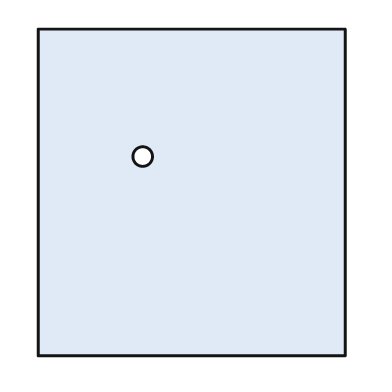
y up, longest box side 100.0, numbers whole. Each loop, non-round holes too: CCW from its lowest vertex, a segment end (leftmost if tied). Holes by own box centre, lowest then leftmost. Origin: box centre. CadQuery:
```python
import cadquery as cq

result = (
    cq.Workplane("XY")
    .moveTo(-47.0, -50.0)
    .lineTo(47.0, -50.0)
    .lineTo(47.0, 50.0)
    .lineTo(-47.0, 50.0)
    .close()
    .moveTo(-15.0, 11.0)
    .circle(3.0)
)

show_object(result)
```